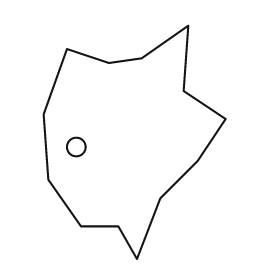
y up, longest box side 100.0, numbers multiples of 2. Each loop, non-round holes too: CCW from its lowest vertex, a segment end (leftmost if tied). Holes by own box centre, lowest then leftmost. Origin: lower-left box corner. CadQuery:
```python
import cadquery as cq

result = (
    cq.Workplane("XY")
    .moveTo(40.0, 0.0)
    .lineTo(50.0, 26.0)
    .lineTo(66.0, 42.0)
    .lineTo(78.0, 60.0)
    .lineTo(60.0, 72.0)
    .lineTo(62.0, 100.0)
    .lineTo(42.0, 86.0)
    .lineTo(28.0, 84.0)
    .lineTo(10.0, 90.0)
    .lineTo(0.0, 62.0)
    .lineTo(2.0, 34.0)
    .lineTo(16.0, 14.0)
    .lineTo(32.0, 14.0)
    .close()
    .moveTo(14.0, 48.0)
    .circle(4.0)
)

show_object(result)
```